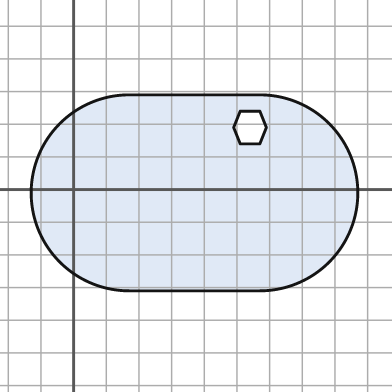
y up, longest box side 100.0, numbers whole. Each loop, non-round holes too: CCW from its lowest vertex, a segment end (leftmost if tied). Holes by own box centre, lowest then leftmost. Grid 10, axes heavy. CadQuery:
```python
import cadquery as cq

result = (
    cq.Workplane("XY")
    .moveTo(17.0, -31.0)
    .lineTo(57.0, -31.0)
    .threePointArc((87.0, -1.0), (57.0, 29.0))
    .lineTo(17.0, 29.0)
    .threePointArc((-13.0, -1.0), (17.0, -31.0))
    .close()
    .moveTo(51.0, 14.0)
    .lineTo(57.0, 14.0)
    .lineTo(59.0, 19.0)
    .lineTo(57.0, 24.0)
    .lineTo(51.0, 24.0)
    .lineTo(49.0, 19.0)
    .close()
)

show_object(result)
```